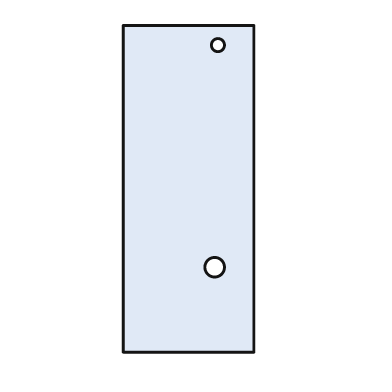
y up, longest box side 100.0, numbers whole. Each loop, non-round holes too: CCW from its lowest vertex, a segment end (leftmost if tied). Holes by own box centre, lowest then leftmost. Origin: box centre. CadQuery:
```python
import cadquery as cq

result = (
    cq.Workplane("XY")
    .moveTo(-20.0, -50.0)
    .lineTo(20.0, -50.0)
    .lineTo(20.0, 50.0)
    .lineTo(-20.0, 50.0)
    .close()
    .moveTo(8.0, -24.0)
    .circle(3.0)
    .moveTo(9.0, 44.0)
    .circle(2.0)
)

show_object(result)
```